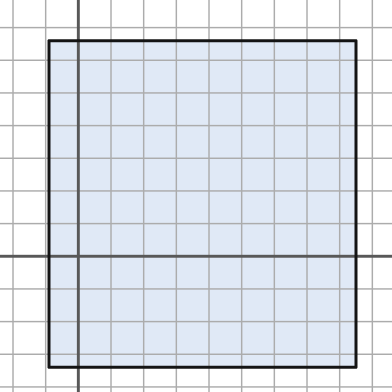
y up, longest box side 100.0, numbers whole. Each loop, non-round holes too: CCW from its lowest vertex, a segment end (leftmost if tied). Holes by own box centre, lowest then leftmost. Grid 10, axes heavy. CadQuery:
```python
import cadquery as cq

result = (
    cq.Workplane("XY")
    .moveTo(-9.0, -34.0)
    .lineTo(85.0, -34.0)
    .lineTo(85.0, 66.0)
    .lineTo(-9.0, 66.0)
    .close()
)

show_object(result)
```